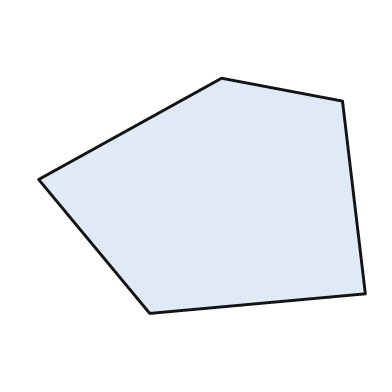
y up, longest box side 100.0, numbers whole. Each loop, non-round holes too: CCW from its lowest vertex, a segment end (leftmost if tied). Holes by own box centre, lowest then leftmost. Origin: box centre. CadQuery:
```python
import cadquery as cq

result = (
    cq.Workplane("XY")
    .moveTo(-16.0, -36.0)
    .lineTo(50.0, -30.0)
    .lineTo(43.0, 29.0)
    .lineTo(6.0, 36.0)
    .lineTo(-50.0, 5.0)
    .close()
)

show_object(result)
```